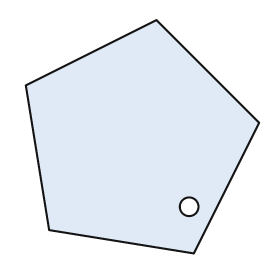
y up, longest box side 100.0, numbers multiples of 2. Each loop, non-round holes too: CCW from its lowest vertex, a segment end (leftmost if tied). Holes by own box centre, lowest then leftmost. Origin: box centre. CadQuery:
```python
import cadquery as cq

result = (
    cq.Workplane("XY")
    .moveTo(22.0, -50.0)
    .lineTo(50.0, 6.0)
    .lineTo(6.0, 50.0)
    .lineTo(-50.0, 22.0)
    .lineTo(-40.0, -40.0)
    .close()
    .moveTo(20.0, -30.0)
    .circle(4.0)
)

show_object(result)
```